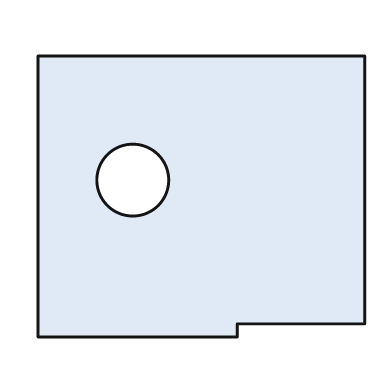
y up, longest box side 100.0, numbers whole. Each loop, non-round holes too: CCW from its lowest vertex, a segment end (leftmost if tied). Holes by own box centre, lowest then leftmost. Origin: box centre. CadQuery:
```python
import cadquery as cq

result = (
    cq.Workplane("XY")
    .moveTo(-50.0, -43.0)
    .lineTo(11.0, -43.0)
    .lineTo(11.0, -39.0)
    .lineTo(50.0, -39.0)
    .lineTo(50.0, 43.0)
    .lineTo(-50.0, 43.0)
    .close()
    .moveTo(-21.0, 5.0)
    .circle(11.0)
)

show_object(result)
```